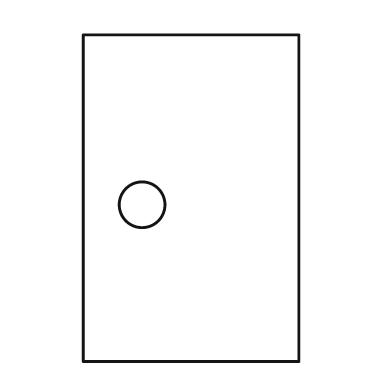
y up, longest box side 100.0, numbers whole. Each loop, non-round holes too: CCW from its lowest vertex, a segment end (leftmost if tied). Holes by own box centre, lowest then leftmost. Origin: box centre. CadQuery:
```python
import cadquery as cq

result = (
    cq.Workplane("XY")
    .moveTo(-33.0, -50.0)
    .lineTo(33.0, -50.0)
    .lineTo(33.0, 50.0)
    .lineTo(-33.0, 50.0)
    .close()
    .moveTo(-15.0, -2.0)
    .circle(7.0)
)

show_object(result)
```